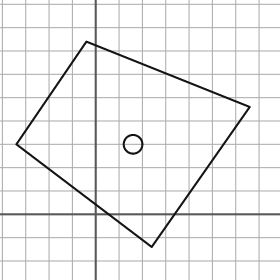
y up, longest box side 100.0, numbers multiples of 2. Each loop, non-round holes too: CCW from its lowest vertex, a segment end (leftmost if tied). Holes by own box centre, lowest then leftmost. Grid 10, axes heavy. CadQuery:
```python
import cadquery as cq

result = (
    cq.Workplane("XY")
    .moveTo(24.0, -14.0)
    .lineTo(66.0, 46.0)
    .lineTo(-4.0, 74.0)
    .lineTo(-34.0, 30.0)
    .close()
    .moveTo(16.0, 30.0)
    .circle(4.0)
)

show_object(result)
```